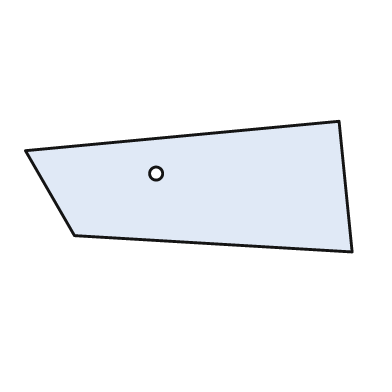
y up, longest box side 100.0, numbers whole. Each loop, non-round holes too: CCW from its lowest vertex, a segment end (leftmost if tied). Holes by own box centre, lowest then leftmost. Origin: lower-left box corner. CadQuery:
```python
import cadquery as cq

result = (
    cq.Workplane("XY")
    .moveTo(100.0, 0.0)
    .lineTo(96.0, 40.0)
    .lineTo(0.0, 31.0)
    .lineTo(15.0, 5.0)
    .close()
    .moveTo(40.0, 24.0)
    .circle(2.0)
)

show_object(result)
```